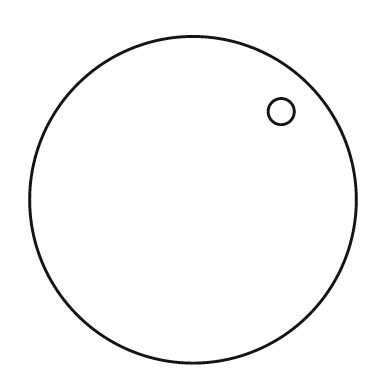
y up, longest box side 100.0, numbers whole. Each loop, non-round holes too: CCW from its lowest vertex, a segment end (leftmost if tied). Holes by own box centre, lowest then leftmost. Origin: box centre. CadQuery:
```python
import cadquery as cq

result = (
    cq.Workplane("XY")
    .moveTo(0.0, 0.0)
    .circle(50.0)
    .moveTo(27.0, 27.0)
    .circle(4.0)
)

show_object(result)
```